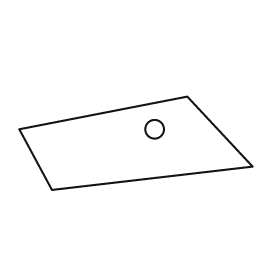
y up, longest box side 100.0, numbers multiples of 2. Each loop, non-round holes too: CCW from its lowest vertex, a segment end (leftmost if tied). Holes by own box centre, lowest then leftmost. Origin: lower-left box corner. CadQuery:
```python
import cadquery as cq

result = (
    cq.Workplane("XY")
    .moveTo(14.0, 0.0)
    .lineTo(100.0, 10.0)
    .lineTo(72.0, 40.0)
    .lineTo(0.0, 26.0)
    .close()
    .moveTo(58.0, 26.0)
    .circle(4.0)
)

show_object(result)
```